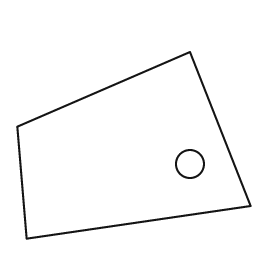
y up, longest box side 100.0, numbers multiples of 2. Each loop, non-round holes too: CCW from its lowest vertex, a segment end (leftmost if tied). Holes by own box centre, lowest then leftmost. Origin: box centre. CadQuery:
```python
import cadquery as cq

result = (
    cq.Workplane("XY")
    .moveTo(-46.0, -40.0)
    .lineTo(50.0, -26.0)
    .lineTo(24.0, 40.0)
    .lineTo(-50.0, 8.0)
    .close()
    .moveTo(24.0, -8.0)
    .circle(6.0)
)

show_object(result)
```